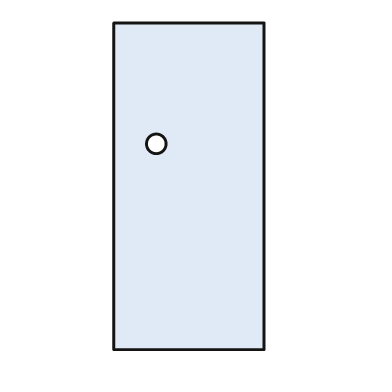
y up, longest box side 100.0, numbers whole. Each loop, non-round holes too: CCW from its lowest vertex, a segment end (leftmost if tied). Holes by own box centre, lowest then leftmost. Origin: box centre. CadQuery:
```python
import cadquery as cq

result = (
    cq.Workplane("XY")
    .moveTo(-23.0, -50.0)
    .lineTo(23.0, -50.0)
    .lineTo(23.0, 50.0)
    .lineTo(-23.0, 50.0)
    .close()
    .moveTo(-10.0, 13.0)
    .circle(3.0)
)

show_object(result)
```